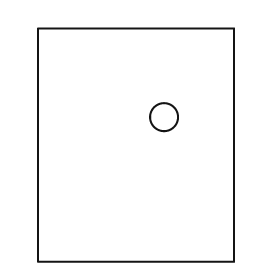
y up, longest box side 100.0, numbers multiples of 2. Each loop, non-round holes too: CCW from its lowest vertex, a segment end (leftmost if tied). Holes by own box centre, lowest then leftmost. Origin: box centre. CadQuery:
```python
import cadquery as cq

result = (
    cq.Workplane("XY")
    .moveTo(-42.0, -50.0)
    .lineTo(42.0, -50.0)
    .lineTo(42.0, 50.0)
    .lineTo(-42.0, 50.0)
    .close()
    .moveTo(12.0, 12.0)
    .circle(6.0)
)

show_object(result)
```